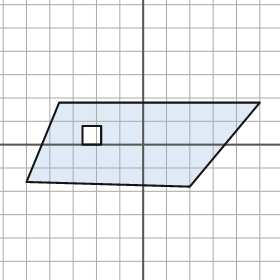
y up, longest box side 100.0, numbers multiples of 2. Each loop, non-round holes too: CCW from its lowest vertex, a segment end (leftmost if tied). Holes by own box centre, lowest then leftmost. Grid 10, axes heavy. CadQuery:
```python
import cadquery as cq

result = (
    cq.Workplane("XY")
    .moveTo(20.0, -18.0)
    .lineTo(50.0, 18.0)
    .lineTo(-36.0, 18.0)
    .lineTo(-50.0, -16.0)
    .close()
    .moveTo(-26.0, 0.0)
    .lineTo(-18.0, 0.0)
    .lineTo(-18.0, 8.0)
    .lineTo(-26.0, 8.0)
    .close()
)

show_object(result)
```